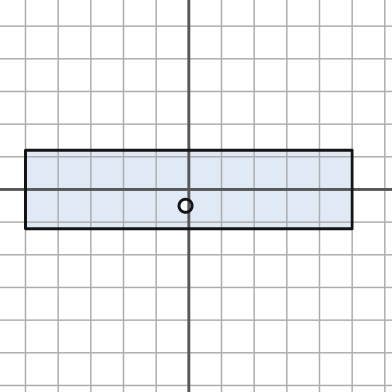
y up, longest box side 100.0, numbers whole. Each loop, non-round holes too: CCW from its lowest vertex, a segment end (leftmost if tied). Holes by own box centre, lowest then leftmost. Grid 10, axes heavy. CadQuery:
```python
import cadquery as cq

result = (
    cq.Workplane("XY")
    .moveTo(-50.0, -12.0)
    .lineTo(50.0, -12.0)
    .lineTo(50.0, 12.0)
    .lineTo(-50.0, 12.0)
    .close()
    .moveTo(-1.0, -5.0)
    .circle(2.0)
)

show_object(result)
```